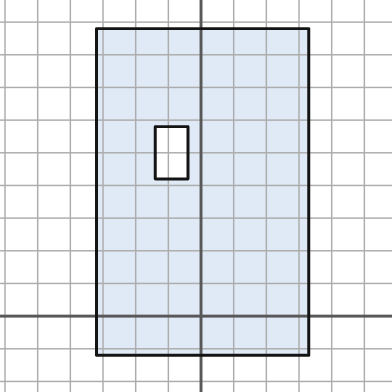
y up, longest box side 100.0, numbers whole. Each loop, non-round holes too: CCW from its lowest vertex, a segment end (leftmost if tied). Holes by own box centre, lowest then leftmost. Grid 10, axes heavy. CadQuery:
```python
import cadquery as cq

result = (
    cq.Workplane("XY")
    .moveTo(-32.0, -12.0)
    .lineTo(33.0, -12.0)
    .lineTo(33.0, 88.0)
    .lineTo(-32.0, 88.0)
    .close()
    .moveTo(-14.0, 42.0)
    .lineTo(-4.0, 42.0)
    .lineTo(-4.0, 58.0)
    .lineTo(-14.0, 58.0)
    .close()
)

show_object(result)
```